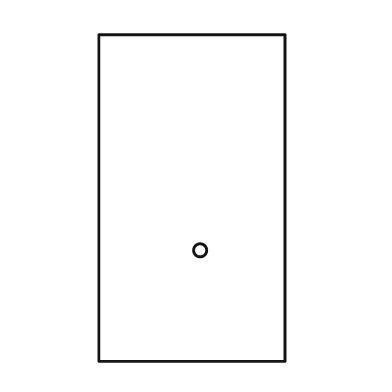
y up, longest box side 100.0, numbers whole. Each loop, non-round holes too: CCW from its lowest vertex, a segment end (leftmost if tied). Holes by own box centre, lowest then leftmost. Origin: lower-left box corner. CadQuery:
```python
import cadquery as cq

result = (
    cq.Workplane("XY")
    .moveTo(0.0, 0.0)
    .lineTo(57.0, 0.0)
    .lineTo(57.0, 100.0)
    .lineTo(0.0, 100.0)
    .close()
    .moveTo(31.0, 34.0)
    .circle(2.0)
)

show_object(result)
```